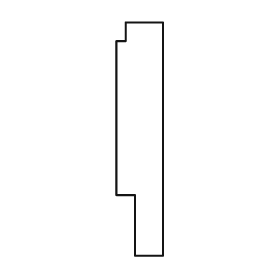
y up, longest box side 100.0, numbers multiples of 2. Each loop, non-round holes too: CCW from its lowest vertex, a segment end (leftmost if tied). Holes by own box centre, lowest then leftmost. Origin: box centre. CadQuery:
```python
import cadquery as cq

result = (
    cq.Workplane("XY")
    .moveTo(-2.0, -50.0)
    .lineTo(10.0, -50.0)
    .lineTo(10.0, 50.0)
    .lineTo(-6.0, 50.0)
    .lineTo(-6.0, 42.0)
    .lineTo(-10.0, 42.0)
    .lineTo(-10.0, -24.0)
    .lineTo(-2.0, -24.0)
    .close()
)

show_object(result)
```